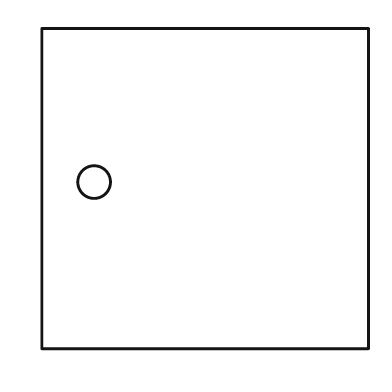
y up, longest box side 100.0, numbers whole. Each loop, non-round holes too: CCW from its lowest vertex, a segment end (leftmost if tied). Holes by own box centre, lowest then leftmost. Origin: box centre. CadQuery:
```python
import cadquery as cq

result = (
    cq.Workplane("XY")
    .moveTo(-50.0, -49.0)
    .lineTo(50.0, -49.0)
    .lineTo(50.0, 49.0)
    .lineTo(-50.0, 49.0)
    .close()
    .moveTo(-34.0, 2.0)
    .circle(5.0)
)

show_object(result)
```